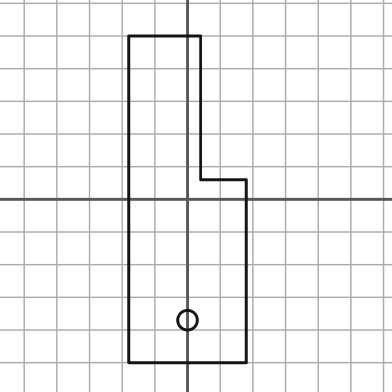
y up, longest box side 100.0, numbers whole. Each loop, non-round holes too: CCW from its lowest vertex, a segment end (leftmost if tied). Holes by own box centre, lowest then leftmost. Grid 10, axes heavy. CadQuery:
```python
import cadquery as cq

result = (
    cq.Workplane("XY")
    .moveTo(-18.0, -50.0)
    .lineTo(18.0, -50.0)
    .lineTo(18.0, 6.0)
    .lineTo(4.0, 6.0)
    .lineTo(4.0, 50.0)
    .lineTo(-18.0, 50.0)
    .close()
    .moveTo(0.0, -37.0)
    .circle(3.0)
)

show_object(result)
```